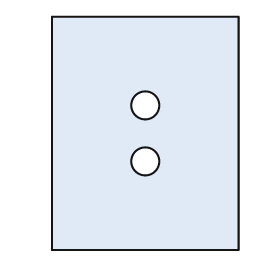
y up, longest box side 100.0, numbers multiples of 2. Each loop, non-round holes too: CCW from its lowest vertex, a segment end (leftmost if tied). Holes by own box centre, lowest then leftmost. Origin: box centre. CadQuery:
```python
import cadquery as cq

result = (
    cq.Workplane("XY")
    .moveTo(-40.0, -50.0)
    .lineTo(40.0, -50.0)
    .lineTo(40.0, 50.0)
    .lineTo(-40.0, 50.0)
    .close()
    .moveTo(0.0, -12.0)
    .circle(6.0)
    .moveTo(0.0, 12.0)
    .circle(6.0)
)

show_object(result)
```